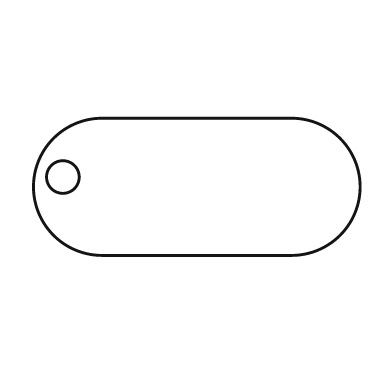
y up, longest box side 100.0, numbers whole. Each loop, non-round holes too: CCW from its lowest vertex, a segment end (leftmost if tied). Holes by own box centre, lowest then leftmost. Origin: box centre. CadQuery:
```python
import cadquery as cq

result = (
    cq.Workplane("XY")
    .moveTo(-29.0, -21.0)
    .lineTo(29.0, -21.0)
    .threePointArc((50.0, 0.0), (29.0, 21.0))
    .lineTo(-29.0, 21.0)
    .threePointArc((-50.0, 0.0), (-29.0, -21.0))
    .close()
    .moveTo(-41.0, 3.0)
    .circle(5.0)
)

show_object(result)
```